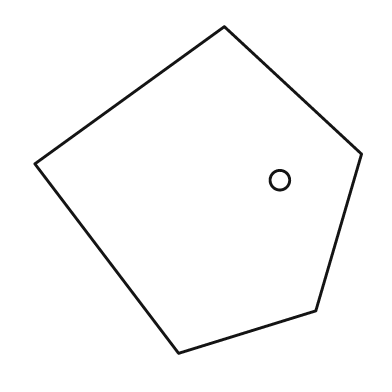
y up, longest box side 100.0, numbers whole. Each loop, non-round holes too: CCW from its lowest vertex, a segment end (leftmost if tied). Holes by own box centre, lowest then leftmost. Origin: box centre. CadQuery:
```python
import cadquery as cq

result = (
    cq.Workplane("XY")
    .moveTo(-6.0, -50.0)
    .lineTo(36.0, -37.0)
    .lineTo(50.0, 11.0)
    .lineTo(8.0, 50.0)
    .lineTo(-50.0, 8.0)
    .close()
    .moveTo(25.0, 3.0)
    .circle(3.0)
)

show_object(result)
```